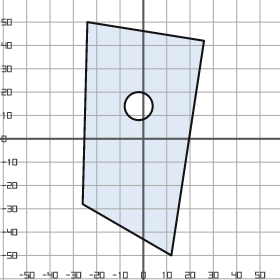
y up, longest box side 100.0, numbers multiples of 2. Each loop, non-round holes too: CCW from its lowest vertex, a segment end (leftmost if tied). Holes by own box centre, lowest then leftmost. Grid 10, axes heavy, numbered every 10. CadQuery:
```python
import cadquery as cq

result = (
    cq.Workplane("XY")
    .moveTo(12.0, -50.0)
    .lineTo(26.0, 42.0)
    .lineTo(-24.0, 50.0)
    .lineTo(-26.0, -28.0)
    .close()
    .moveTo(-2.0, 14.0)
    .circle(6.0)
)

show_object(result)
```